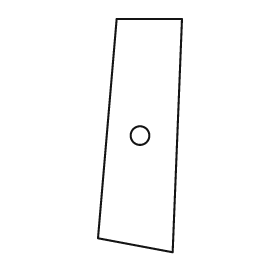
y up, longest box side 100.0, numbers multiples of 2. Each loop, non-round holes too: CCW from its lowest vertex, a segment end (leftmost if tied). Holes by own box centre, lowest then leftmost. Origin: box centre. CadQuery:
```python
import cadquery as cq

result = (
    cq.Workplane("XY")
    .moveTo(14.0, -50.0)
    .lineTo(18.0, 50.0)
    .lineTo(-10.0, 50.0)
    .lineTo(-18.0, -44.0)
    .close()
    .moveTo(0.0, 0.0)
    .circle(4.0)
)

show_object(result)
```